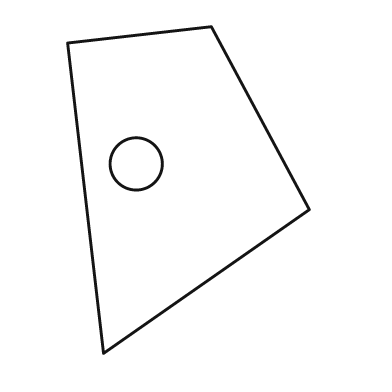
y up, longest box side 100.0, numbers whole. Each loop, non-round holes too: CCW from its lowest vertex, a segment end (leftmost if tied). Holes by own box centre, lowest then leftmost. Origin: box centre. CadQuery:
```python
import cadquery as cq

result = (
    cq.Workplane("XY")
    .moveTo(-26.0, -50.0)
    .lineTo(37.0, -6.0)
    .lineTo(7.0, 50.0)
    .lineTo(-37.0, 45.0)
    .close()
    .moveTo(-16.0, 8.0)
    .circle(8.0)
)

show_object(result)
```